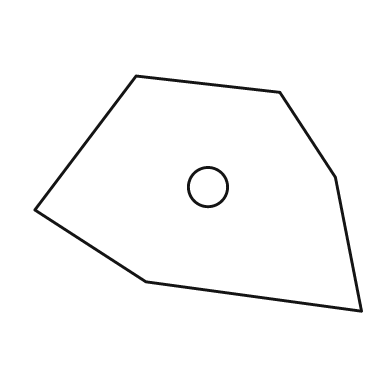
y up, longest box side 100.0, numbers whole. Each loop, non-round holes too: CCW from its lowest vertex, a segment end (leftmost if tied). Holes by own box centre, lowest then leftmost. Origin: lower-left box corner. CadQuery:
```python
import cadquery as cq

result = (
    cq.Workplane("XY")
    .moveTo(100.0, 0.0)
    .lineTo(92.0, 41.0)
    .lineTo(75.0, 67.0)
    .lineTo(31.0, 72.0)
    .lineTo(0.0, 31.0)
    .lineTo(34.0, 9.0)
    .close()
    .moveTo(53.0, 38.0)
    .circle(6.0)
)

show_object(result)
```